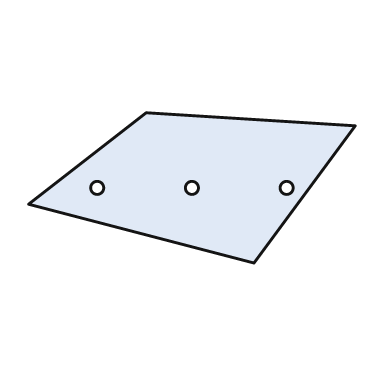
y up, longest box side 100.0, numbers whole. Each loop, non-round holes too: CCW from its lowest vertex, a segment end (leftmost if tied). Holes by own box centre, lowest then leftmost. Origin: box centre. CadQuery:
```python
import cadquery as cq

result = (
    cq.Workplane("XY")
    .moveTo(19.0, -23.0)
    .lineTo(50.0, 19.0)
    .lineTo(-14.0, 23.0)
    .lineTo(-50.0, -5.0)
    .close()
    .moveTo(-29.0, 0.0)
    .circle(2.0)
    .moveTo(0.0, 0.0)
    .circle(2.0)
    .moveTo(29.0, 0.0)
    .circle(2.0)
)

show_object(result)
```